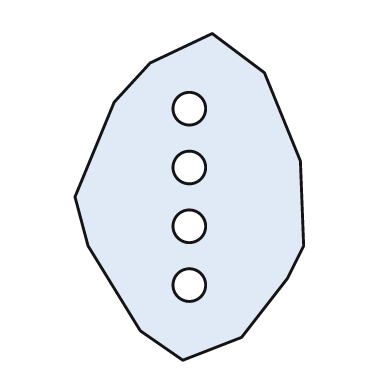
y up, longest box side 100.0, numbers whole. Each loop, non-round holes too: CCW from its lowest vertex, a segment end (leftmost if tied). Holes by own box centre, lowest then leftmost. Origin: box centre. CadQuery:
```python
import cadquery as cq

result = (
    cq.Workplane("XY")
    .moveTo(-2.0, -50.0)
    .lineTo(16.0, -43.0)
    .lineTo(30.0, -25.0)
    .lineTo(35.0, -15.0)
    .lineTo(34.0, 11.0)
    .lineTo(23.0, 38.0)
    .lineTo(7.0, 50.0)
    .lineTo(-12.0, 41.0)
    .lineTo(-23.0, 29.0)
    .lineTo(-35.0, 0.0)
    .lineTo(-31.0, -15.0)
    .lineTo(-15.0, -41.0)
    .close()
    .moveTo(0.0, -27.0)
    .circle(5.0)
    .moveTo(0.0, -9.0)
    .circle(5.0)
    .moveTo(0.0, 9.0)
    .circle(5.0)
    .moveTo(0.0, 27.0)
    .circle(5.0)
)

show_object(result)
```